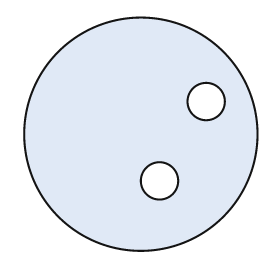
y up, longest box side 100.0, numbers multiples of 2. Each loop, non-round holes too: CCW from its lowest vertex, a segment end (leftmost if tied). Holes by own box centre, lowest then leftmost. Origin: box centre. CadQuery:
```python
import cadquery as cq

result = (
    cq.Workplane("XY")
    .moveTo(0.0, 0.0)
    .circle(50.0)
    .moveTo(8.0, -20.0)
    .circle(8.0)
    .moveTo(28.0, 14.0)
    .circle(8.0)
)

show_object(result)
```